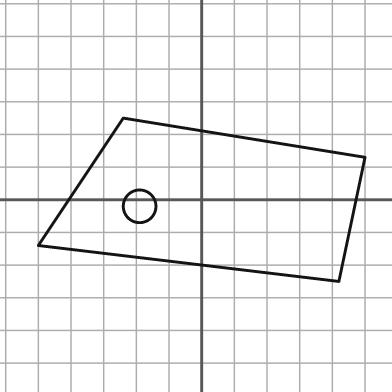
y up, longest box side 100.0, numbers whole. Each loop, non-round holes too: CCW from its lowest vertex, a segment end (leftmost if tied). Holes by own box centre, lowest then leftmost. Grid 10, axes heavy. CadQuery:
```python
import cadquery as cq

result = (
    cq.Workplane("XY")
    .moveTo(42.0, -25.0)
    .lineTo(50.0, 13.0)
    .lineTo(-24.0, 25.0)
    .lineTo(-50.0, -14.0)
    .close()
    .moveTo(-19.0, -2.0)
    .circle(5.0)
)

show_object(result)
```